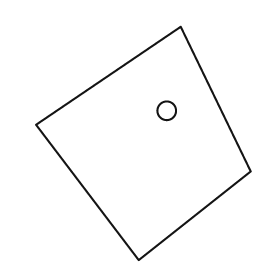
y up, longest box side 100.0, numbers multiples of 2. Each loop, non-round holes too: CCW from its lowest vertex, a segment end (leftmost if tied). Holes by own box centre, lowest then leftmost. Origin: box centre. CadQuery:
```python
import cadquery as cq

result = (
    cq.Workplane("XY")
    .moveTo(-2.0, -50.0)
    .lineTo(46.0, -12.0)
    .lineTo(16.0, 50.0)
    .lineTo(-46.0, 8.0)
    .close()
    .moveTo(10.0, 14.0)
    .circle(4.0)
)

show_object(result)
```